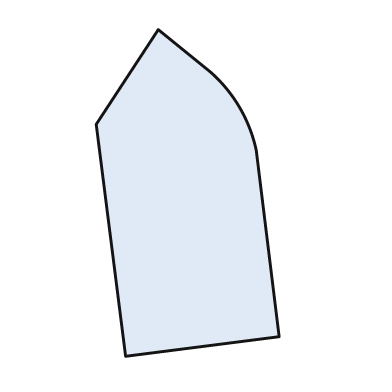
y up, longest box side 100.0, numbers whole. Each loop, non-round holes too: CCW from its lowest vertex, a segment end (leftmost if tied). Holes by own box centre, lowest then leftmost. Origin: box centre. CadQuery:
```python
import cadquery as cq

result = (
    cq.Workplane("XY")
    .moveTo(-19.0, -50.0)
    .lineTo(28.0, -44.0)
    .lineTo(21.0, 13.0)
    .threePointArc((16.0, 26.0), (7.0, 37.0))
    .lineTo(-9.0, 50.0)
    .lineTo(-28.0, 21.0)
    .close()
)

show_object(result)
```